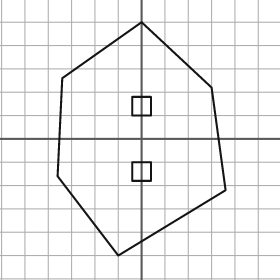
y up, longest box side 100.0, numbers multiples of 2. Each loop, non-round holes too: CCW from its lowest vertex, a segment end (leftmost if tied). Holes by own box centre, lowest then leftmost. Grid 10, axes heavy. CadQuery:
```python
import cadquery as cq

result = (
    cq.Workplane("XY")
    .moveTo(-10.0, -50.0)
    .lineTo(36.0, -22.0)
    .lineTo(30.0, 22.0)
    .lineTo(0.0, 50.0)
    .lineTo(-34.0, 26.0)
    .lineTo(-36.0, -16.0)
    .close()
    .moveTo(-4.0, -18.0)
    .lineTo(4.0, -18.0)
    .lineTo(4.0, -10.0)
    .lineTo(-4.0, -10.0)
    .close()
    .moveTo(-4.0, 10.0)
    .lineTo(4.0, 10.0)
    .lineTo(4.0, 18.0)
    .lineTo(-4.0, 18.0)
    .close()
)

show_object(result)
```